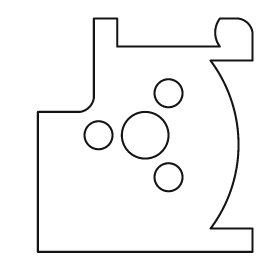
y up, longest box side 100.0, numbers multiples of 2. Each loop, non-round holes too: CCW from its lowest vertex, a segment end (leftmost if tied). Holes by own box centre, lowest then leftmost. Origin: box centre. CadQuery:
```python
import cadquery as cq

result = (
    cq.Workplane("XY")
    .moveTo(-46.0, -50.0)
    .lineTo(46.0, -50.0)
    .lineTo(46.0, -40.0)
    .lineTo(28.0, -40.0)
    .threePointArc((40.0, -4.0), (28.0, 32.0))
    .lineTo(46.0, 32.0)
    .lineTo(46.0, 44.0)
    .threePointArc((44.0, 48.0), (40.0, 50.0))
    .lineTo(32.0, 50.0)
    .threePointArc((30.0, 44.0), (32.0, 38.0))
    .lineTo(-12.0, 38.0)
    .lineTo(-12.0, 50.0)
    .lineTo(-22.0, 50.0)
    .lineTo(-22.0, 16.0)
    .threePointArc((-24.0, 12.0), (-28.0, 10.0))
    .lineTo(-46.0, 10.0)
    .close()
    .moveTo(10.0, -18.0)
    .circle(6.0)
    .moveTo(-20.0, 0.0)
    .circle(6.0)
    .moveTo(0.0, 0.0)
    .circle(10.0)
    .moveTo(10.0, 18.0)
    .circle(6.0)
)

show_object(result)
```